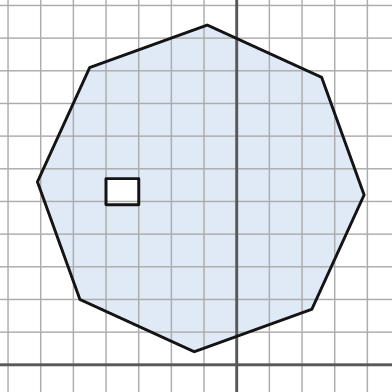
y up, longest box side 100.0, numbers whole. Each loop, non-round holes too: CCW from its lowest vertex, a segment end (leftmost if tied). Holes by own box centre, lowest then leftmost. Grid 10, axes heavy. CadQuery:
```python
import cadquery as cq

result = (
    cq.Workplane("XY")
    .moveTo(-13.0, 4.0)
    .lineTo(23.0, 17.0)
    .lineTo(39.0, 52.0)
    .lineTo(26.0, 88.0)
    .lineTo(-9.0, 104.0)
    .lineTo(-45.0, 91.0)
    .lineTo(-61.0, 56.0)
    .lineTo(-48.0, 20.0)
    .close()
    .moveTo(-40.0, 49.0)
    .lineTo(-30.0, 49.0)
    .lineTo(-30.0, 57.0)
    .lineTo(-40.0, 57.0)
    .close()
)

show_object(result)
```